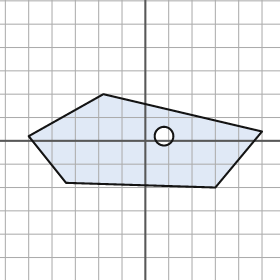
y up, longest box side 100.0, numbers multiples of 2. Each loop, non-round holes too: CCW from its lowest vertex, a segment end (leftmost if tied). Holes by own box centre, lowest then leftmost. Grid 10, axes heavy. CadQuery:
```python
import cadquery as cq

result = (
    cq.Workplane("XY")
    .moveTo(30.0, -20.0)
    .lineTo(50.0, 4.0)
    .lineTo(-18.0, 20.0)
    .lineTo(-50.0, 2.0)
    .lineTo(-34.0, -18.0)
    .close()
    .moveTo(8.0, 2.0)
    .circle(4.0)
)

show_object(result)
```